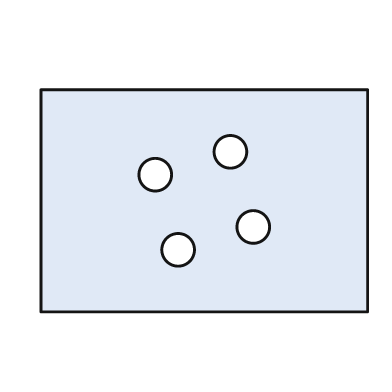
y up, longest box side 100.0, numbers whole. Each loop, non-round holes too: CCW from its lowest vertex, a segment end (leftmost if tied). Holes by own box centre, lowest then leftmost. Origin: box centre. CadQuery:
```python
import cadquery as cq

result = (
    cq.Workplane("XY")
    .moveTo(-50.0, -34.0)
    .lineTo(50.0, -34.0)
    .lineTo(50.0, 34.0)
    .lineTo(-50.0, 34.0)
    .close()
    .moveTo(-8.0, -15.0)
    .circle(5.0)
    .moveTo(15.0, -8.0)
    .circle(5.0)
    .moveTo(-15.0, 8.0)
    .circle(5.0)
    .moveTo(8.0, 15.0)
    .circle(5.0)
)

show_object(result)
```